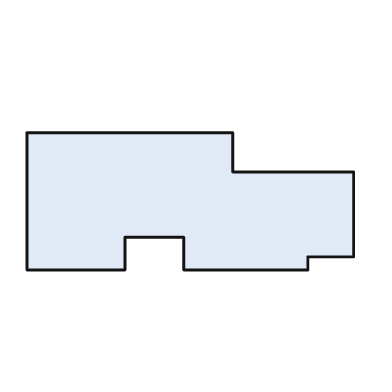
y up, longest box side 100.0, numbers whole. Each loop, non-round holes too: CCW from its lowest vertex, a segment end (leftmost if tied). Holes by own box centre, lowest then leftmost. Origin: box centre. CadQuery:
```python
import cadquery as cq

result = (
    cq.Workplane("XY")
    .moveTo(-50.0, -21.0)
    .lineTo(-20.0, -21.0)
    .lineTo(-20.0, -11.0)
    .lineTo(-2.0, -11.0)
    .lineTo(-2.0, -21.0)
    .lineTo(36.0, -21.0)
    .lineTo(36.0, -17.0)
    .lineTo(50.0, -17.0)
    .lineTo(50.0, 9.0)
    .lineTo(13.0, 9.0)
    .lineTo(13.0, 21.0)
    .lineTo(-50.0, 21.0)
    .close()
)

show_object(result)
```